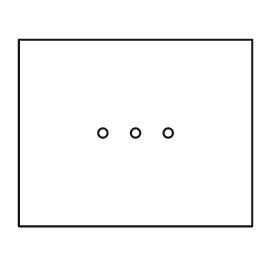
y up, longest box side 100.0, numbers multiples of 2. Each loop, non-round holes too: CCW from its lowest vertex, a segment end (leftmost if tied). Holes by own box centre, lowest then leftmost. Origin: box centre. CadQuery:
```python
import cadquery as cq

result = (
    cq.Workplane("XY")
    .moveTo(-50.0, -40.0)
    .lineTo(50.0, -40.0)
    .lineTo(50.0, 40.0)
    .lineTo(-50.0, 40.0)
    .close()
    .moveTo(-14.0, 0.0)
    .circle(2.0)
    .moveTo(0.0, 0.0)
    .circle(2.0)
    .moveTo(14.0, 0.0)
    .circle(2.0)
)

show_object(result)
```